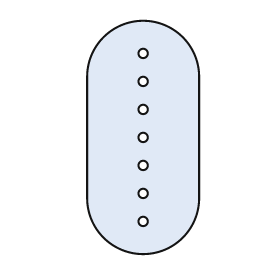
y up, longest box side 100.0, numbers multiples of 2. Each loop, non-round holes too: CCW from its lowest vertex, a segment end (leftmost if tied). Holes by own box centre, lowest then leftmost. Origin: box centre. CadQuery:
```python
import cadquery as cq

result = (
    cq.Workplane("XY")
    .moveTo(-24.0, -26.0)
    .threePointArc((0.0, -50.0), (24.0, -26.0))
    .lineTo(24.0, 26.0)
    .threePointArc((0.0, 50.0), (-24.0, 26.0))
    .close()
    .moveTo(0.0, -36.0)
    .circle(2.0)
    .moveTo(0.0, -24.0)
    .circle(2.0)
    .moveTo(0.0, -12.0)
    .circle(2.0)
    .moveTo(0.0, 0.0)
    .circle(2.0)
    .moveTo(0.0, 12.0)
    .circle(2.0)
    .moveTo(0.0, 24.0)
    .circle(2.0)
    .moveTo(0.0, 36.0)
    .circle(2.0)
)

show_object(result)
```